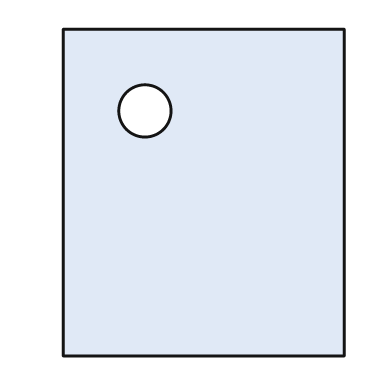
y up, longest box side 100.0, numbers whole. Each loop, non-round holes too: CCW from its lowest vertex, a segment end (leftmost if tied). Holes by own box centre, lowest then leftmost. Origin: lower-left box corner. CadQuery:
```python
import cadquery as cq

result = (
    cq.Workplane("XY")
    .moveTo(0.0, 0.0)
    .lineTo(86.0, 0.0)
    .lineTo(86.0, 100.0)
    .lineTo(0.0, 100.0)
    .close()
    .moveTo(25.0, 75.0)
    .circle(8.0)
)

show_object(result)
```